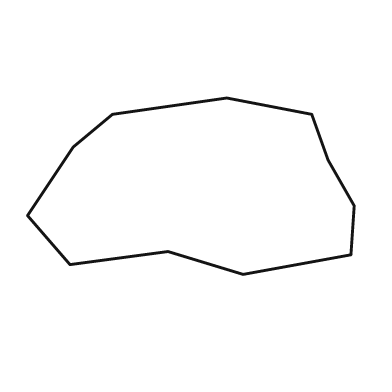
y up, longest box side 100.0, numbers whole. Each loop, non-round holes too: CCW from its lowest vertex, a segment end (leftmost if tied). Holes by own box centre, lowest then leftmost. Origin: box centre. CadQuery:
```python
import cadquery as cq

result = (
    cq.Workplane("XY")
    .moveTo(16.0, -27.0)
    .lineTo(49.0, -21.0)
    .lineTo(50.0, -6.0)
    .lineTo(42.0, 8.0)
    .lineTo(37.0, 22.0)
    .lineTo(11.0, 27.0)
    .lineTo(-24.0, 22.0)
    .lineTo(-36.0, 12.0)
    .lineTo(-50.0, -9.0)
    .lineTo(-37.0, -24.0)
    .lineTo(-7.0, -20.0)
    .close()
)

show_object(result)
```